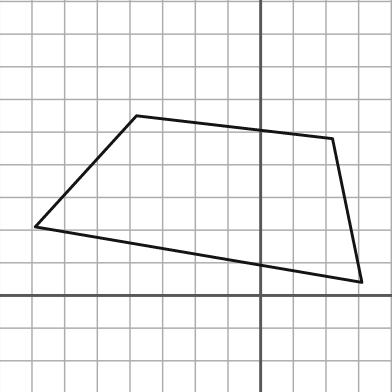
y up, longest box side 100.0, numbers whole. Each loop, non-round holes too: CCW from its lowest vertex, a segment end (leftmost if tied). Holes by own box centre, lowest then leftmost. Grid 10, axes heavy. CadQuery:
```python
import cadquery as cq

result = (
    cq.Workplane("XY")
    .moveTo(31.0, 4.0)
    .lineTo(22.0, 48.0)
    .lineTo(-38.0, 55.0)
    .lineTo(-69.0, 21.0)
    .close()
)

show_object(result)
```